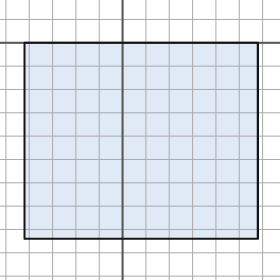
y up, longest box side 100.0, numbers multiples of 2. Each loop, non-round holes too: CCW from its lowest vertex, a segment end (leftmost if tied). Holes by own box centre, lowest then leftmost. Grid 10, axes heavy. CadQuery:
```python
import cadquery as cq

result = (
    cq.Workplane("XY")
    .moveTo(-42.0, -84.0)
    .lineTo(58.0, -84.0)
    .lineTo(58.0, 0.0)
    .lineTo(-42.0, 0.0)
    .close()
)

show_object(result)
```